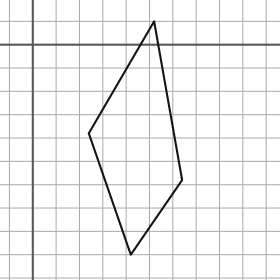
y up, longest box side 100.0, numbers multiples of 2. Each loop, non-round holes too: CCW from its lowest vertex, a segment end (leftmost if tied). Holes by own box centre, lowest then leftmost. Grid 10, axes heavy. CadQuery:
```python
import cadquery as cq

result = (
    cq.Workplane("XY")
    .moveTo(42.0, -90.0)
    .lineTo(64.0, -58.0)
    .lineTo(52.0, 10.0)
    .lineTo(24.0, -38.0)
    .close()
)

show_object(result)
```